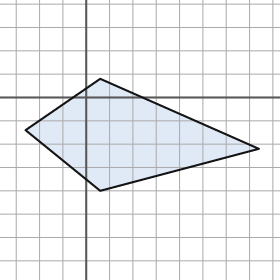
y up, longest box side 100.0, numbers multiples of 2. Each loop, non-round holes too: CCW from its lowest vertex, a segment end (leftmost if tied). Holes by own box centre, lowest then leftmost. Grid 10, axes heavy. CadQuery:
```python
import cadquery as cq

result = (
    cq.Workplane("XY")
    .moveTo(6.0, -40.0)
    .lineTo(74.0, -22.0)
    .lineTo(6.0, 8.0)
    .lineTo(-26.0, -14.0)
    .close()
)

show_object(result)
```